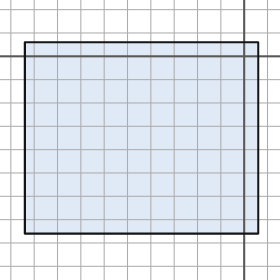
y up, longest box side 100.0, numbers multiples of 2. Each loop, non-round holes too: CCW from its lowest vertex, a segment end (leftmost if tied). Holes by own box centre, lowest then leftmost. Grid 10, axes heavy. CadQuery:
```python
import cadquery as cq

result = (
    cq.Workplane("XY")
    .moveTo(-94.0, -76.0)
    .lineTo(6.0, -76.0)
    .lineTo(6.0, 6.0)
    .lineTo(-94.0, 6.0)
    .close()
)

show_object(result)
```